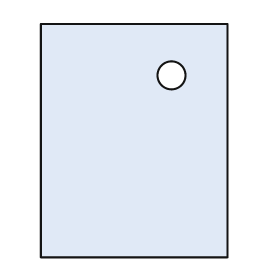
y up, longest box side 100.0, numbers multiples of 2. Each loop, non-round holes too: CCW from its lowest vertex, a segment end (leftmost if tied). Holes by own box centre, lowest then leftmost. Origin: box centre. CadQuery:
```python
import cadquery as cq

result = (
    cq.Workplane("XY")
    .moveTo(-40.0, -50.0)
    .lineTo(40.0, -50.0)
    .lineTo(40.0, 50.0)
    .lineTo(-40.0, 50.0)
    .close()
    .moveTo(16.0, 28.0)
    .circle(6.0)
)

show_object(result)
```